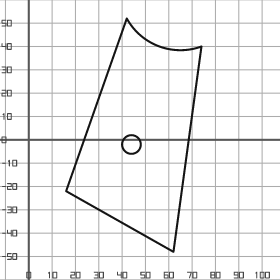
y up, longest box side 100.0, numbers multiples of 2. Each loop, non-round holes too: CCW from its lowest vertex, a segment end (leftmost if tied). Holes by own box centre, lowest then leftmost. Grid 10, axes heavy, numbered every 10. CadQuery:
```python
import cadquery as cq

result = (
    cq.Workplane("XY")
    .moveTo(62.0, -48.0)
    .lineTo(74.0, 40.0)
    .threePointArc((56.0, 40.0), (42.0, 52.0))
    .lineTo(16.0, -22.0)
    .close()
    .moveTo(44.0, -2.0)
    .circle(4.0)
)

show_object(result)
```